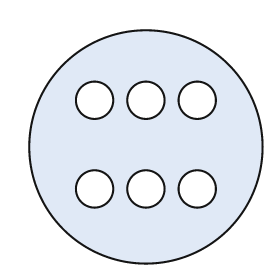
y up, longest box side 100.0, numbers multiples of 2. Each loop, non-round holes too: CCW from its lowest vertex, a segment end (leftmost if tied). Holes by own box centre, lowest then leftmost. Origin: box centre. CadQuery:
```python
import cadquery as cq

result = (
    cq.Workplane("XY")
    .moveTo(0.0, 0.0)
    .circle(50.0)
    .moveTo(-22.0, -18.0)
    .circle(8.0)
    .moveTo(0.0, -18.0)
    .circle(8.0)
    .moveTo(22.0, -18.0)
    .circle(8.0)
    .moveTo(-22.0, 20.0)
    .circle(8.0)
    .moveTo(0.0, 20.0)
    .circle(8.0)
    .moveTo(22.0, 20.0)
    .circle(8.0)
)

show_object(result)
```